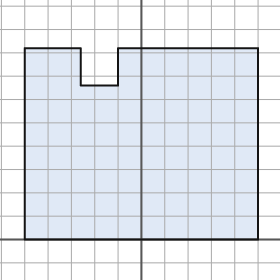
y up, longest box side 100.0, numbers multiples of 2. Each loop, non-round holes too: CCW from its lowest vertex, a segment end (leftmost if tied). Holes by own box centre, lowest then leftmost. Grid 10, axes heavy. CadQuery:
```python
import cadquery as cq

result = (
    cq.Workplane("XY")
    .moveTo(-50.0, 0.0)
    .lineTo(50.0, 0.0)
    .lineTo(50.0, 82.0)
    .lineTo(-10.0, 82.0)
    .lineTo(-10.0, 66.0)
    .lineTo(-26.0, 66.0)
    .lineTo(-26.0, 82.0)
    .lineTo(-50.0, 82.0)
    .close()
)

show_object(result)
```